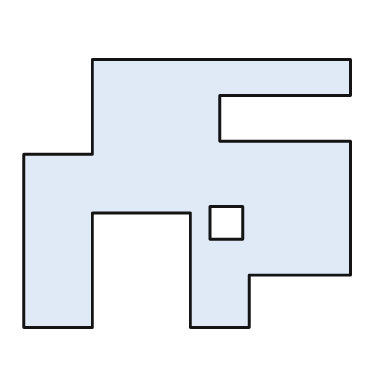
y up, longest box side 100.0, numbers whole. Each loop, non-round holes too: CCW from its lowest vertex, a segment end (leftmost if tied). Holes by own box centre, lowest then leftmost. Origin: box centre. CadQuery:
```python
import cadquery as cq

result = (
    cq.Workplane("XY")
    .moveTo(-50.0, -41.0)
    .lineTo(-29.0, -41.0)
    .lineTo(-29.0, -6.0)
    .lineTo(1.0, -6.0)
    .lineTo(1.0, -41.0)
    .lineTo(19.0, -41.0)
    .lineTo(19.0, -25.0)
    .lineTo(50.0, -25.0)
    .lineTo(50.0, 16.0)
    .lineTo(10.0, 16.0)
    .lineTo(10.0, 30.0)
    .lineTo(50.0, 30.0)
    .lineTo(50.0, 41.0)
    .lineTo(-29.0, 41.0)
    .lineTo(-29.0, 12.0)
    .lineTo(-50.0, 12.0)
    .close()
    .moveTo(7.0, -14.0)
    .lineTo(17.0, -14.0)
    .lineTo(17.0, -4.0)
    .lineTo(7.0, -4.0)
    .close()
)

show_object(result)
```